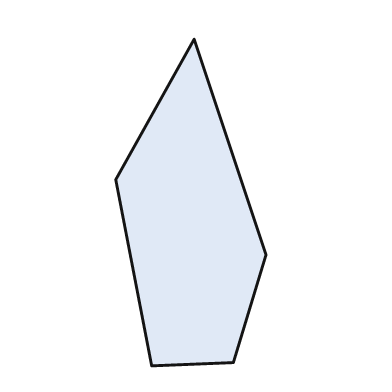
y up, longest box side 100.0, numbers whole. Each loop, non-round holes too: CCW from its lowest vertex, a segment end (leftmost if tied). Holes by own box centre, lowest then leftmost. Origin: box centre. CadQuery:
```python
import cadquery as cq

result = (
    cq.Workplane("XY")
    .moveTo(-12.0, -50.0)
    .lineTo(13.0, -49.0)
    .lineTo(23.0, -16.0)
    .lineTo(1.0, 50.0)
    .lineTo(-23.0, 7.0)
    .close()
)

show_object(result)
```